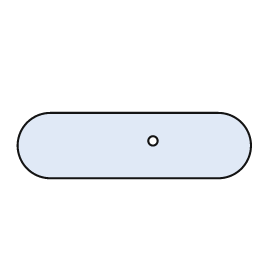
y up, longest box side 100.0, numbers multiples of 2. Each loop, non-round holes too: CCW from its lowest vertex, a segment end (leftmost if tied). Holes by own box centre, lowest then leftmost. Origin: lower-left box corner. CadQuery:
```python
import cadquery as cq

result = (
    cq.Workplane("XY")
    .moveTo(14.0, 0.0)
    .lineTo(86.0, 0.0)
    .threePointArc((100.0, 14.0), (86.0, 28.0))
    .lineTo(14.0, 28.0)
    .threePointArc((0.0, 14.0), (14.0, 0.0))
    .close()
    .moveTo(58.0, 16.0)
    .circle(2.0)
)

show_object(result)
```